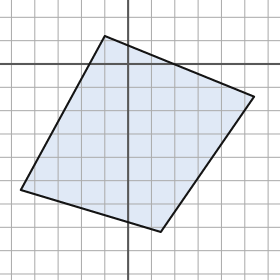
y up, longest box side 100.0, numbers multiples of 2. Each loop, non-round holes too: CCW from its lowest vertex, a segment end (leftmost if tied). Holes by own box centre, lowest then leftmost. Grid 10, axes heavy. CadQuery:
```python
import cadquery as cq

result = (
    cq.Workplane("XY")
    .moveTo(14.0, -72.0)
    .lineTo(54.0, -14.0)
    .lineTo(-10.0, 12.0)
    .lineTo(-46.0, -54.0)
    .close()
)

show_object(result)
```